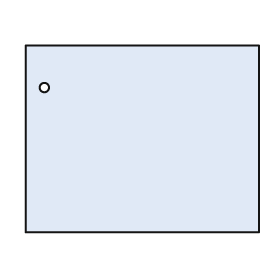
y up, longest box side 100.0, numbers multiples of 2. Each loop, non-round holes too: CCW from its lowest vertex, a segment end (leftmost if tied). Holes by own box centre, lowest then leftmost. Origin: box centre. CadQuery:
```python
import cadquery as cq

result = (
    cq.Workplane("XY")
    .moveTo(-50.0, -40.0)
    .lineTo(50.0, -40.0)
    .lineTo(50.0, 40.0)
    .lineTo(-50.0, 40.0)
    .close()
    .moveTo(-42.0, 22.0)
    .circle(2.0)
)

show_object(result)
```